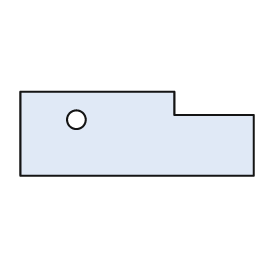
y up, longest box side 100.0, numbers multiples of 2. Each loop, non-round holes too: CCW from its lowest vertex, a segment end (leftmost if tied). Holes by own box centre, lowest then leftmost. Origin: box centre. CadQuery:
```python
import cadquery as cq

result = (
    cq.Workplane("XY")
    .moveTo(-50.0, -18.0)
    .lineTo(50.0, -18.0)
    .lineTo(50.0, 8.0)
    .lineTo(16.0, 8.0)
    .lineTo(16.0, 18.0)
    .lineTo(-50.0, 18.0)
    .close()
    .moveTo(-26.0, 6.0)
    .circle(4.0)
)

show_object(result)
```